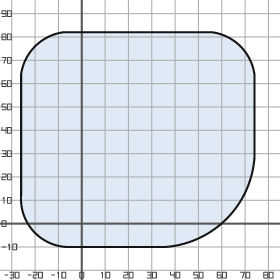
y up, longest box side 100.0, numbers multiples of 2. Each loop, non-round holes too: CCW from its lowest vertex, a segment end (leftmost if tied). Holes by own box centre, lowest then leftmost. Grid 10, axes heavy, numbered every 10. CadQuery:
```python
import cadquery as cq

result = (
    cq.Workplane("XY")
    .moveTo(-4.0, -10.0)
    .lineTo(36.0, -10.0)
    .threePointArc((62.0, 2.0), (74.0, 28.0))
    .lineTo(74.0, 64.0)
    .threePointArc((68.0, 76.0), (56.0, 82.0))
    .lineTo(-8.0, 82.0)
    .threePointArc((-20.0, 76.0), (-26.0, 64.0))
    .lineTo(-26.0, 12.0)
    .threePointArc((-20.0, -4.0), (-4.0, -10.0))
    .close()
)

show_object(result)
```